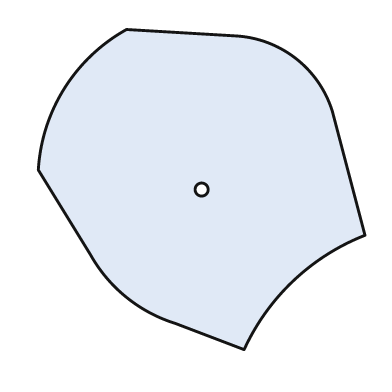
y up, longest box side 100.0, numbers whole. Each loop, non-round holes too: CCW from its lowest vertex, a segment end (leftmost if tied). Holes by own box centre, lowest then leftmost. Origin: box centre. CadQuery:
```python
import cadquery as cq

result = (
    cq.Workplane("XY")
    .moveTo(13.0, -49.0)
    .threePointArc((28.0, -28.0), (50.0, -14.0))
    .lineTo(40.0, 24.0)
    .threePointArc((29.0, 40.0), (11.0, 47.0))
    .lineTo(-23.0, 49.0)
    .threePointArc((-42.0, 31.0), (-50.0, 6.0))
    .lineTo(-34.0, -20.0)
    .threePointArc((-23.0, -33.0), (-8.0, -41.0))
    .close()
    .moveTo(0.0, 0.0)
    .circle(2.0)
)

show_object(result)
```